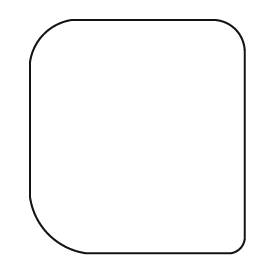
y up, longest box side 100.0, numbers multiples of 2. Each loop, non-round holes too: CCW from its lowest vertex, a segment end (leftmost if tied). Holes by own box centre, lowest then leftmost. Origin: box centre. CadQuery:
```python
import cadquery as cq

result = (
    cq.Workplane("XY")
    .moveTo(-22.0, -50.0)
    .lineTo(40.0, -50.0)
    .threePointArc((44.0, -48.0), (46.0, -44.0))
    .lineTo(46.0, 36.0)
    .threePointArc((42.0, 46.0), (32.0, 50.0))
    .lineTo(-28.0, 50.0)
    .threePointArc((-40.0, 44.0), (-46.0, 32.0))
    .lineTo(-46.0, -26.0)
    .threePointArc((-38.0, -42.0), (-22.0, -50.0))
    .close()
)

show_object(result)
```